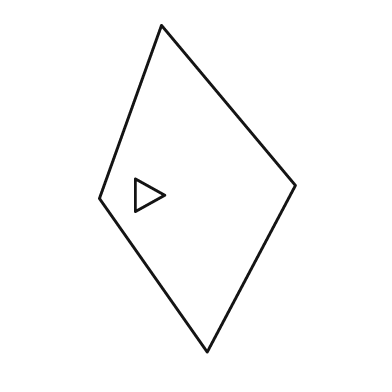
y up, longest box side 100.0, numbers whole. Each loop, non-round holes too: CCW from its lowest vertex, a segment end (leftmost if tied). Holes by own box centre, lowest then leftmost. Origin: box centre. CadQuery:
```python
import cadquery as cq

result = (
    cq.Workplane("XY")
    .moveTo(3.0, -50.0)
    .lineTo(30.0, 1.0)
    .lineTo(-11.0, 50.0)
    .lineTo(-30.0, -3.0)
    .close()
    .moveTo(-19.0, -7.0)
    .lineTo(-10.0, -2.0)
    .lineTo(-19.0, 3.0)
    .close()
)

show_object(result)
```